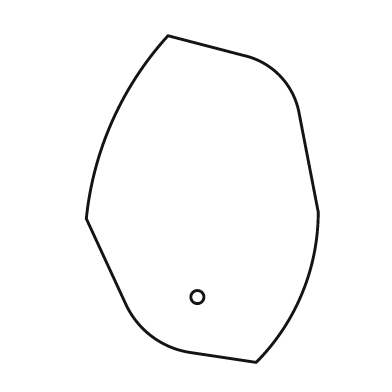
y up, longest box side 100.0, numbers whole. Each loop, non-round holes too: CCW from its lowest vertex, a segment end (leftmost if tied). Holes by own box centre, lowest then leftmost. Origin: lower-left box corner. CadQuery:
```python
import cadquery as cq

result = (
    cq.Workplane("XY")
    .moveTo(52.0, 0.0)
    .threePointArc((66.0, 21.0), (71.0, 46.0))
    .lineTo(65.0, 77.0)
    .threePointArc((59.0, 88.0), (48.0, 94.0))
    .lineTo(25.0, 100.0)
    .threePointArc((8.0, 74.0), (0.0, 44.0))
    .lineTo(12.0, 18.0)
    .threePointArc((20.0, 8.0), (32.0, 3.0))
    .close()
    .moveTo(34.0, 20.0)
    .circle(2.0)
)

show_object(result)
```